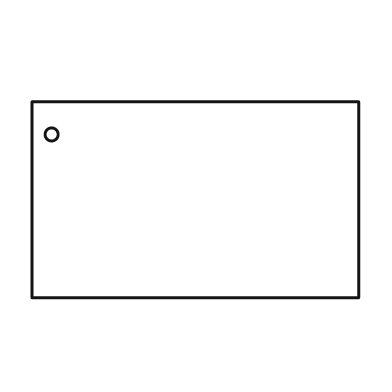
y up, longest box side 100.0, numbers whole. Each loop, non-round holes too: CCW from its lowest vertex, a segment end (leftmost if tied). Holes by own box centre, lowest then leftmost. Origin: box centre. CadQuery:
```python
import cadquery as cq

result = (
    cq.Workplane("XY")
    .moveTo(-50.0, -30.0)
    .lineTo(50.0, -30.0)
    .lineTo(50.0, 30.0)
    .lineTo(-50.0, 30.0)
    .close()
    .moveTo(-44.0, 20.0)
    .circle(2.0)
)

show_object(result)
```